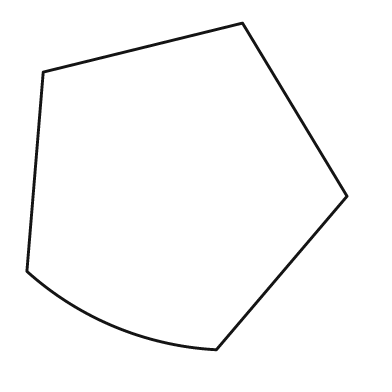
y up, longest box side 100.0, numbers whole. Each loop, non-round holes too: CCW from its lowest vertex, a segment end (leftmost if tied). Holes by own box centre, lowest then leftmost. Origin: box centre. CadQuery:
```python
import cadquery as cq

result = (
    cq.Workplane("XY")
    .moveTo(9.0, -50.0)
    .lineTo(49.0, -3.0)
    .lineTo(17.0, 50.0)
    .lineTo(-44.0, 35.0)
    .lineTo(-49.0, -26.0)
    .threePointArc((-22.0, -43.0), (9.0, -50.0))
    .close()
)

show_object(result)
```